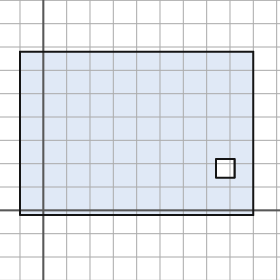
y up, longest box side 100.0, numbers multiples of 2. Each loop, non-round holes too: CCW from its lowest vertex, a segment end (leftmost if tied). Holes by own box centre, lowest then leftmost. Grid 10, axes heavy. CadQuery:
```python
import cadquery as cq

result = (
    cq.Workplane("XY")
    .moveTo(-10.0, -2.0)
    .lineTo(90.0, -2.0)
    .lineTo(90.0, 68.0)
    .lineTo(-10.0, 68.0)
    .close()
    .moveTo(74.0, 14.0)
    .lineTo(82.0, 14.0)
    .lineTo(82.0, 22.0)
    .lineTo(74.0, 22.0)
    .close()
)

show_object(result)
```